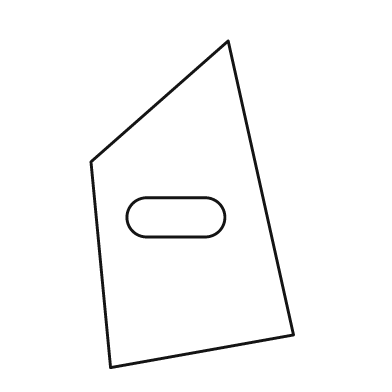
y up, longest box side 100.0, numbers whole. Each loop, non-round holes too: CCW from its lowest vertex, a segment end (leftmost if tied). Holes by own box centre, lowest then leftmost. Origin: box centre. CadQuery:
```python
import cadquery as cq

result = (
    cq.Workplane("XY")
    .moveTo(-25.0, -50.0)
    .lineTo(31.0, -40.0)
    .lineTo(11.0, 50.0)
    .lineTo(-31.0, 13.0)
    .close()
    .moveTo(-14.0, -10.0)
    .lineTo(4.0, -10.0)
    .threePointArc((10.0, -4.0), (4.0, 2.0))
    .lineTo(-14.0, 2.0)
    .threePointArc((-20.0, -4.0), (-14.0, -10.0))
    .close()
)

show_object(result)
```